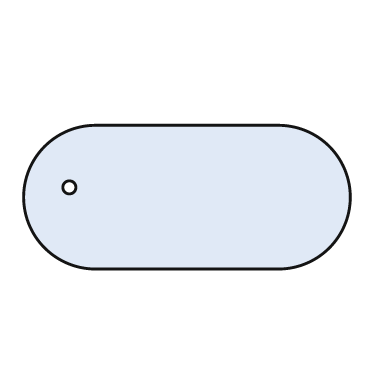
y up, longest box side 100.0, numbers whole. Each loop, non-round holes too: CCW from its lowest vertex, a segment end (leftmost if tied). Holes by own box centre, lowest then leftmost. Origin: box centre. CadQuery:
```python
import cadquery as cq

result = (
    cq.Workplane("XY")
    .moveTo(-28.0, -22.0)
    .lineTo(28.0, -22.0)
    .threePointArc((50.0, 0.0), (28.0, 22.0))
    .lineTo(-28.0, 22.0)
    .threePointArc((-50.0, 0.0), (-28.0, -22.0))
    .close()
    .moveTo(-36.0, 3.0)
    .circle(2.0)
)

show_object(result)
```